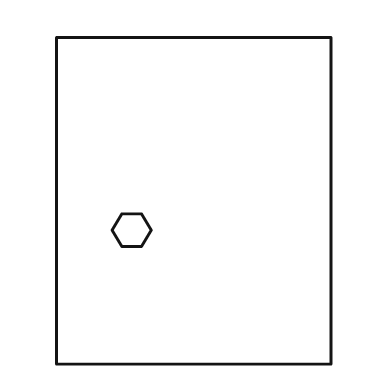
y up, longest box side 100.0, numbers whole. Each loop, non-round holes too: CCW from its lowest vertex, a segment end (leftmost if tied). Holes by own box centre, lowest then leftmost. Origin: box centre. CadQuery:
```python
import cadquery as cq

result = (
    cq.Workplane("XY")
    .moveTo(-42.0, -50.0)
    .lineTo(42.0, -50.0)
    .lineTo(42.0, 50.0)
    .lineTo(-42.0, 50.0)
    .close()
    .moveTo(-22.0, -14.0)
    .lineTo(-16.0, -14.0)
    .lineTo(-13.0, -9.0)
    .lineTo(-16.0, -4.0)
    .lineTo(-22.0, -4.0)
    .lineTo(-25.0, -9.0)
    .close()
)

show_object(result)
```